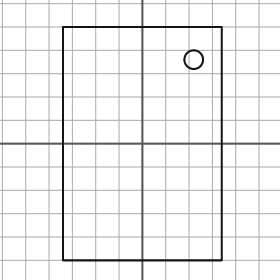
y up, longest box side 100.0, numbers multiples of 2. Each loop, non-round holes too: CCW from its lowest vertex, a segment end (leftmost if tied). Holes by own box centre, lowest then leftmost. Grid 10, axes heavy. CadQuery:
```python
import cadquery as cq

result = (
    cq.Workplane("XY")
    .moveTo(-34.0, -50.0)
    .lineTo(34.0, -50.0)
    .lineTo(34.0, 50.0)
    .lineTo(-34.0, 50.0)
    .close()
    .moveTo(22.0, 36.0)
    .circle(4.0)
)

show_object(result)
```